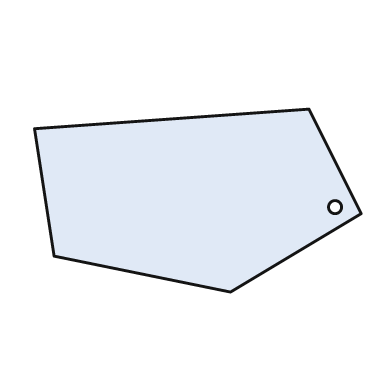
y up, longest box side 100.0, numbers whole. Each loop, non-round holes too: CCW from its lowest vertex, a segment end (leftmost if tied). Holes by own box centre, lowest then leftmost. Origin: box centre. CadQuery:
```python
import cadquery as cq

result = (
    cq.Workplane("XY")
    .moveTo(10.0, -28.0)
    .lineTo(50.0, -4.0)
    .lineTo(34.0, 28.0)
    .lineTo(-50.0, 22.0)
    .lineTo(-44.0, -17.0)
    .close()
    .moveTo(42.0, -2.0)
    .circle(2.0)
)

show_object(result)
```